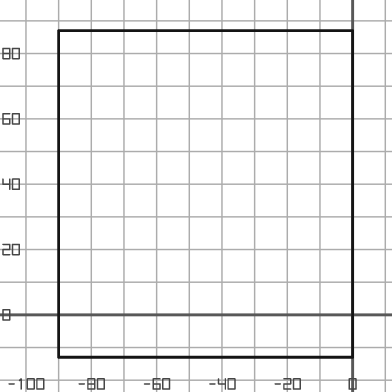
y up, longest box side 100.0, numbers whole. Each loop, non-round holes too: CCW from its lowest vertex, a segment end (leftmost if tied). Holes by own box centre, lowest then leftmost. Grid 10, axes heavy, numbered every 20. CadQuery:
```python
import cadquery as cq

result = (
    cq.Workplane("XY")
    .moveTo(-90.0, -13.0)
    .lineTo(0.0, -13.0)
    .lineTo(0.0, 87.0)
    .lineTo(-90.0, 87.0)
    .close()
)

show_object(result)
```